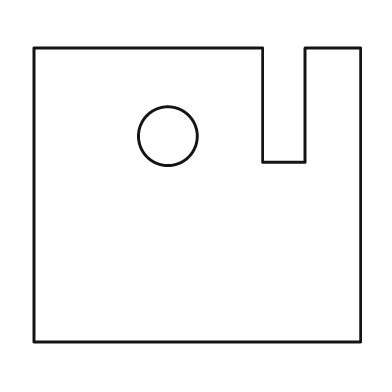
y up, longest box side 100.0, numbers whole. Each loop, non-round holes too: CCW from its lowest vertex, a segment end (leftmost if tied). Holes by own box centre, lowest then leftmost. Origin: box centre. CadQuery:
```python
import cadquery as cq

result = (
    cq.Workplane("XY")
    .moveTo(-50.0, -45.0)
    .lineTo(50.0, -45.0)
    .lineTo(50.0, 45.0)
    .lineTo(33.0, 45.0)
    .lineTo(33.0, 10.0)
    .lineTo(20.0, 10.0)
    .lineTo(20.0, 45.0)
    .lineTo(-50.0, 45.0)
    .close()
    .moveTo(-9.0, 18.0)
    .circle(9.0)
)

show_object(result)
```